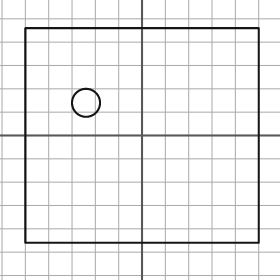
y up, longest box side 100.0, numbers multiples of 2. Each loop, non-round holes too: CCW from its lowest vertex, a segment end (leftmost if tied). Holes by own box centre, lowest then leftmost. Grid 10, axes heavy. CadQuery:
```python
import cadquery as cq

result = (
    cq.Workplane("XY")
    .moveTo(-50.0, -46.0)
    .lineTo(50.0, -46.0)
    .lineTo(50.0, 46.0)
    .lineTo(-50.0, 46.0)
    .close()
    .moveTo(-24.0, 14.0)
    .circle(6.0)
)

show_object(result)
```